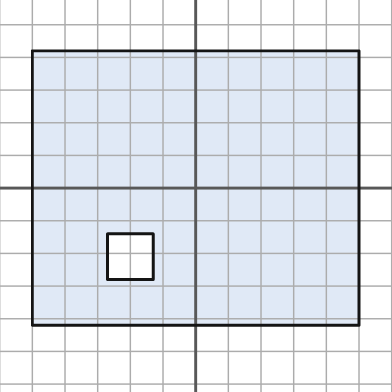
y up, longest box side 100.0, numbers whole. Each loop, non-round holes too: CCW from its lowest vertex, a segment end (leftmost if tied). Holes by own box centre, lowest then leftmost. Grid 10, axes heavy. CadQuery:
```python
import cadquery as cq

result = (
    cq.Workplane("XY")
    .moveTo(-50.0, -42.0)
    .lineTo(50.0, -42.0)
    .lineTo(50.0, 42.0)
    .lineTo(-50.0, 42.0)
    .close()
    .moveTo(-27.0, -28.0)
    .lineTo(-13.0, -28.0)
    .lineTo(-13.0, -14.0)
    .lineTo(-27.0, -14.0)
    .close()
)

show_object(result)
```